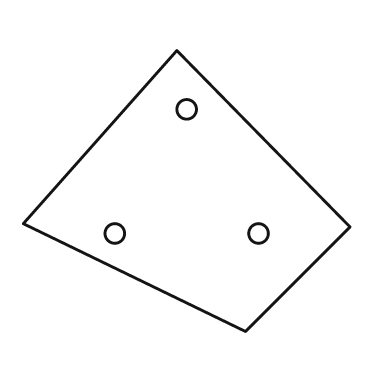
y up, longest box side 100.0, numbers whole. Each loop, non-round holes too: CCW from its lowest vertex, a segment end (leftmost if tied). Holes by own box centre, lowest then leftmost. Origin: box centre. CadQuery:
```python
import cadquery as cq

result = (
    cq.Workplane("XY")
    .moveTo(18.0, -43.0)
    .lineTo(50.0, -11.0)
    .lineTo(-3.0, 43.0)
    .lineTo(-50.0, -10.0)
    .close()
    .moveTo(-22.0, -13.0)
    .circle(3.0)
    .moveTo(22.0, -13.0)
    .circle(3.0)
    .moveTo(0.0, 25.0)
    .circle(3.0)
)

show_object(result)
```